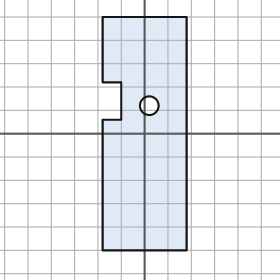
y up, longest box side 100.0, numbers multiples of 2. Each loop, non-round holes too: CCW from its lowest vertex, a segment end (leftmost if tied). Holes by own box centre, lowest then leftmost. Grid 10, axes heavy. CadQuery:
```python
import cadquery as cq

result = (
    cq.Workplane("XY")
    .moveTo(-18.0, -50.0)
    .lineTo(18.0, -50.0)
    .lineTo(18.0, 50.0)
    .lineTo(-18.0, 50.0)
    .lineTo(-18.0, 22.0)
    .lineTo(-10.0, 22.0)
    .lineTo(-10.0, 6.0)
    .lineTo(-18.0, 6.0)
    .close()
    .moveTo(2.0, 12.0)
    .circle(4.0)
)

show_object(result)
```